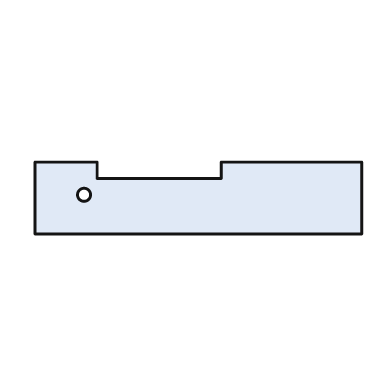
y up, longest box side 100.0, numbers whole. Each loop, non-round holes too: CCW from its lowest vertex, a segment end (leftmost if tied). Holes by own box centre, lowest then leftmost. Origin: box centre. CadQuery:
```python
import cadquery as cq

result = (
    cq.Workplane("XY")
    .moveTo(-50.0, -11.0)
    .lineTo(50.0, -11.0)
    .lineTo(50.0, 11.0)
    .lineTo(7.0, 11.0)
    .lineTo(7.0, 6.0)
    .lineTo(-31.0, 6.0)
    .lineTo(-31.0, 11.0)
    .lineTo(-50.0, 11.0)
    .close()
    .moveTo(-35.0, 1.0)
    .circle(2.0)
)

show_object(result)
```